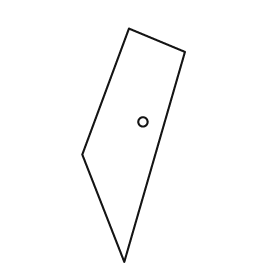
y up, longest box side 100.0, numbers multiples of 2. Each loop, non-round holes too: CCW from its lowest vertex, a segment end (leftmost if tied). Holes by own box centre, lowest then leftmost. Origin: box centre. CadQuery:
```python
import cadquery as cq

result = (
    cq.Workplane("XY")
    .moveTo(-4.0, -50.0)
    .lineTo(22.0, 40.0)
    .lineTo(-2.0, 50.0)
    .lineTo(-22.0, -4.0)
    .close()
    .moveTo(4.0, 10.0)
    .circle(2.0)
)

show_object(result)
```